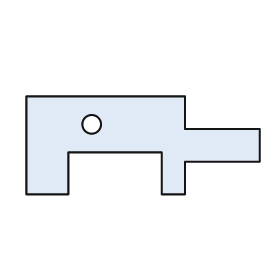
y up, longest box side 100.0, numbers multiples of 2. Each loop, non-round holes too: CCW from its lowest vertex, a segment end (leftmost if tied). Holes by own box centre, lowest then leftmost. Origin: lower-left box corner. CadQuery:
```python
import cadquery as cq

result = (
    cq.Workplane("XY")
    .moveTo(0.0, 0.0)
    .lineTo(18.0, 0.0)
    .lineTo(18.0, 18.0)
    .lineTo(58.0, 18.0)
    .lineTo(58.0, 0.0)
    .lineTo(68.0, 0.0)
    .lineTo(68.0, 14.0)
    .lineTo(100.0, 14.0)
    .lineTo(100.0, 28.0)
    .lineTo(68.0, 28.0)
    .lineTo(68.0, 42.0)
    .lineTo(0.0, 42.0)
    .close()
    .moveTo(28.0, 30.0)
    .circle(4.0)
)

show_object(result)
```